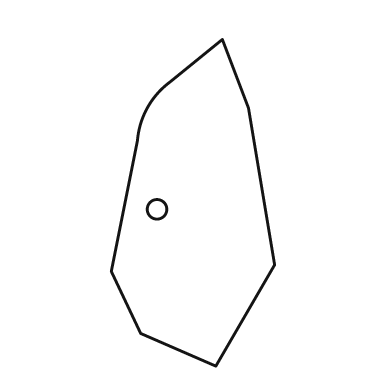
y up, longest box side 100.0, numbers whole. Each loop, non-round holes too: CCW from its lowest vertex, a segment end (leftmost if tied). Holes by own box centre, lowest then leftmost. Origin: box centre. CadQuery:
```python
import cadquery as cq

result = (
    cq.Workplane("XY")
    .moveTo(7.0, -50.0)
    .lineTo(25.0, -19.0)
    .lineTo(17.0, 29.0)
    .lineTo(9.0, 50.0)
    .lineTo(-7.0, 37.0)
    .threePointArc((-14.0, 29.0), (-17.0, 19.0))
    .lineTo(-25.0, -21.0)
    .lineTo(-16.0, -40.0)
    .close()
    .moveTo(-11.0, -2.0)
    .circle(3.0)
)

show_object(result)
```